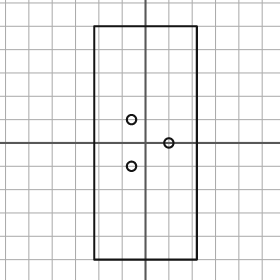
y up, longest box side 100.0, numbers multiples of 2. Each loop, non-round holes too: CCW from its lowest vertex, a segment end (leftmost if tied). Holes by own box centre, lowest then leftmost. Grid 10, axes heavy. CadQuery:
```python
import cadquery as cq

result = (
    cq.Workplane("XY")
    .moveTo(-22.0, -50.0)
    .lineTo(22.0, -50.0)
    .lineTo(22.0, 50.0)
    .lineTo(-22.0, 50.0)
    .close()
    .moveTo(-6.0, -10.0)
    .circle(2.0)
    .moveTo(10.0, 0.0)
    .circle(2.0)
    .moveTo(-6.0, 10.0)
    .circle(2.0)
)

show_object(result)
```